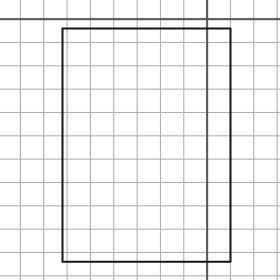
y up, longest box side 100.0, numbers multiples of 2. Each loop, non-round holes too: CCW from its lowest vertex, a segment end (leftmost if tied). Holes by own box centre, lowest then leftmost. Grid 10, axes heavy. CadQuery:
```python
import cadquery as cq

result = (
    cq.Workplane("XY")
    .moveTo(-62.0, -104.0)
    .lineTo(10.0, -104.0)
    .lineTo(10.0, -4.0)
    .lineTo(-62.0, -4.0)
    .close()
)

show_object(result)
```